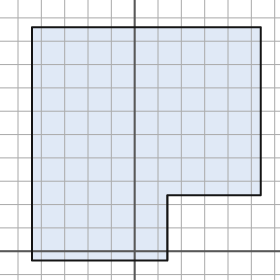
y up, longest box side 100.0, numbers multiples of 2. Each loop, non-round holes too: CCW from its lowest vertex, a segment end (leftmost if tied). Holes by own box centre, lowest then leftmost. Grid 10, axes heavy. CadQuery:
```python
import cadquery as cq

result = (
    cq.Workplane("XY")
    .moveTo(-44.0, -4.0)
    .lineTo(14.0, -4.0)
    .lineTo(14.0, 24.0)
    .lineTo(54.0, 24.0)
    .lineTo(54.0, 96.0)
    .lineTo(-44.0, 96.0)
    .close()
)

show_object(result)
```